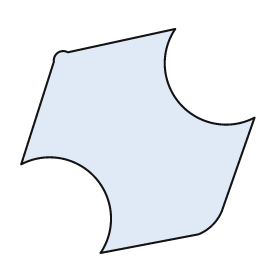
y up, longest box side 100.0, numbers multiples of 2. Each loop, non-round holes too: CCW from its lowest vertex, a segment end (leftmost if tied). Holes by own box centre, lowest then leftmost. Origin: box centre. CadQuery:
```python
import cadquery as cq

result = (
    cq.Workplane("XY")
    .moveTo(-16.0, -48.0)
    .lineTo(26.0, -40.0)
    .threePointArc((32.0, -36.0), (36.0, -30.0))
    .lineTo(50.0, 10.0)
    .threePointArc((18.0, 16.0), (16.0, 48.0))
    .lineTo(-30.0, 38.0)
    .threePointArc((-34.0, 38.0), (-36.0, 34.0))
    .lineTo(-50.0, -10.0)
    .threePointArc((-18.0, -16.0), (-16.0, -48.0))
    .close()
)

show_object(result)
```